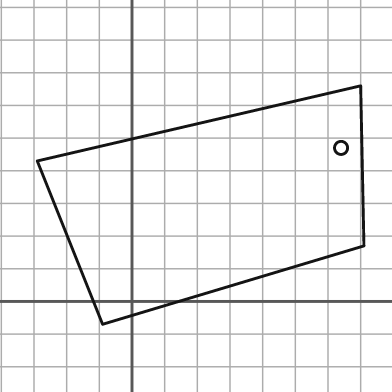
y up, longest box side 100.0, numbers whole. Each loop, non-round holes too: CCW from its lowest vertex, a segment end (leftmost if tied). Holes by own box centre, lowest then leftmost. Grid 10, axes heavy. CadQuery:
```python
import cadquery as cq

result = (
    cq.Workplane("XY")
    .moveTo(-9.0, -7.0)
    .lineTo(71.0, 17.0)
    .lineTo(70.0, 66.0)
    .lineTo(-29.0, 43.0)
    .close()
    .moveTo(64.0, 47.0)
    .circle(2.0)
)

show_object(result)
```